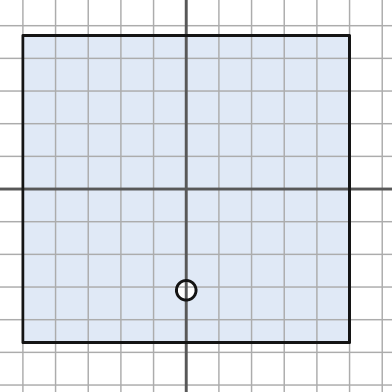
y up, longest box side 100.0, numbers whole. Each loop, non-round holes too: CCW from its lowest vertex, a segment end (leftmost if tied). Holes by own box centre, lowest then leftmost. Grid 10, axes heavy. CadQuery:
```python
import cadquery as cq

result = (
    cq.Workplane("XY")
    .moveTo(-50.0, -47.0)
    .lineTo(50.0, -47.0)
    .lineTo(50.0, 47.0)
    .lineTo(-50.0, 47.0)
    .close()
    .moveTo(0.0, -31.0)
    .circle(3.0)
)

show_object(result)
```